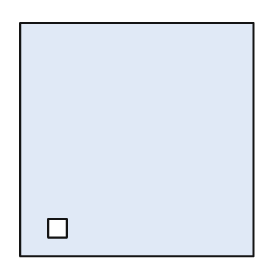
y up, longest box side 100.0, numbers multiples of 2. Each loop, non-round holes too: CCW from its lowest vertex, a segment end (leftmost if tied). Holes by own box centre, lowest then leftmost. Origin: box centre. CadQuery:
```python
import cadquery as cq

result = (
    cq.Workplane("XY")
    .moveTo(-50.0, -50.0)
    .lineTo(50.0, -50.0)
    .lineTo(50.0, 50.0)
    .lineTo(-50.0, 50.0)
    .close()
    .moveTo(-38.0, -42.0)
    .lineTo(-30.0, -42.0)
    .lineTo(-30.0, -34.0)
    .lineTo(-38.0, -34.0)
    .close()
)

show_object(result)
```